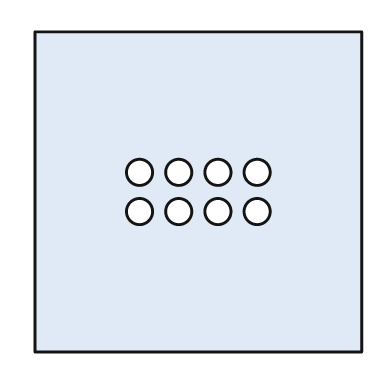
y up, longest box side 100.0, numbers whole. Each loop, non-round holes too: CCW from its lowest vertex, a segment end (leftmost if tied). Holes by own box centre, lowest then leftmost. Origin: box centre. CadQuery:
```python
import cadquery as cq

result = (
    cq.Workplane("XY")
    .moveTo(-50.0, -49.0)
    .lineTo(50.0, -49.0)
    .lineTo(50.0, 49.0)
    .lineTo(-50.0, 49.0)
    .close()
    .moveTo(-18.0, -6.0)
    .circle(4.0)
    .moveTo(-6.0, -6.0)
    .circle(4.0)
    .moveTo(6.0, -6.0)
    .circle(4.0)
    .moveTo(18.0, -6.0)
    .circle(4.0)
    .moveTo(-18.0, 6.0)
    .circle(4.0)
    .moveTo(-6.0, 6.0)
    .circle(4.0)
    .moveTo(6.0, 6.0)
    .circle(4.0)
    .moveTo(18.0, 6.0)
    .circle(4.0)
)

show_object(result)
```